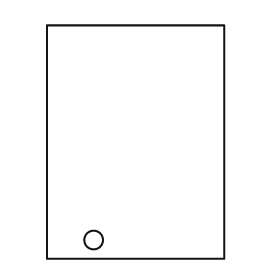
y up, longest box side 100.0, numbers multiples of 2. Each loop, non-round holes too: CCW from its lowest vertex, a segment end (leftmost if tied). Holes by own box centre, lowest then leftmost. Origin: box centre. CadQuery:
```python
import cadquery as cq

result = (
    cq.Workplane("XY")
    .moveTo(-38.0, -50.0)
    .lineTo(38.0, -50.0)
    .lineTo(38.0, 50.0)
    .lineTo(-38.0, 50.0)
    .close()
    .moveTo(-18.0, -42.0)
    .circle(4.0)
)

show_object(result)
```